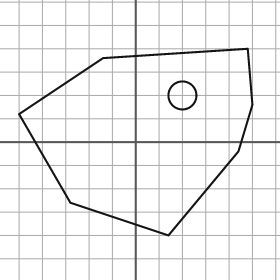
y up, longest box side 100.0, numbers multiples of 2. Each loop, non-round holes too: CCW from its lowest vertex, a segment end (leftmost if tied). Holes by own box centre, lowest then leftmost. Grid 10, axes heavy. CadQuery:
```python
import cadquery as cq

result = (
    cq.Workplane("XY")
    .moveTo(14.0, -40.0)
    .lineTo(44.0, -4.0)
    .lineTo(50.0, 16.0)
    .lineTo(48.0, 40.0)
    .lineTo(-14.0, 36.0)
    .lineTo(-50.0, 12.0)
    .lineTo(-28.0, -26.0)
    .close()
    .moveTo(20.0, 20.0)
    .circle(6.0)
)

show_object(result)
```